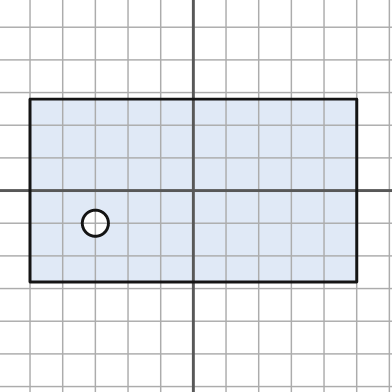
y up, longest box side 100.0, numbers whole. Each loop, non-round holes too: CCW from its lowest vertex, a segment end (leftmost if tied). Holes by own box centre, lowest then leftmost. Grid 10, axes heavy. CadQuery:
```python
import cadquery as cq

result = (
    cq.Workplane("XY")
    .moveTo(-50.0, -28.0)
    .lineTo(50.0, -28.0)
    .lineTo(50.0, 28.0)
    .lineTo(-50.0, 28.0)
    .close()
    .moveTo(-30.0, -10.0)
    .circle(4.0)
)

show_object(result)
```